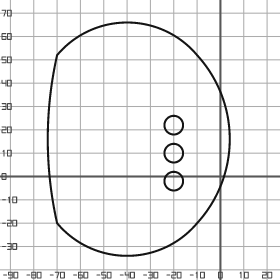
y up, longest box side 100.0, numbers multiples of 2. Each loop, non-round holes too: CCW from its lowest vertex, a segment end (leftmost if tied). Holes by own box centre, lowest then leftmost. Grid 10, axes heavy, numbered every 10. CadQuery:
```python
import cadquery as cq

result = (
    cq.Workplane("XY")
    .moveTo(-70.0, -20.0)
    .threePointArc((-40.0, -34.0), (-10.0, -20.0))
    .threePointArc((4.0, 16.0), (-10.0, 52.0))
    .threePointArc((-40.0, 66.0), (-70.0, 52.0))
    .threePointArc((-74.0, 16.0), (-70.0, -20.0))
    .close()
    .moveTo(-20.0, -2.0)
    .circle(4.0)
    .moveTo(-20.0, 10.0)
    .circle(4.0)
    .moveTo(-20.0, 22.0)
    .circle(4.0)
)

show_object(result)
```